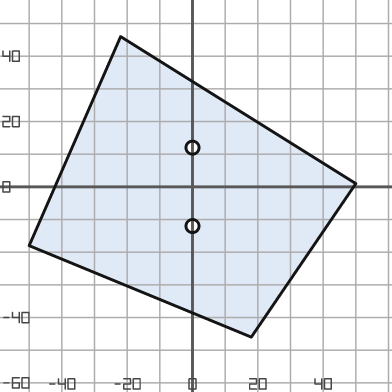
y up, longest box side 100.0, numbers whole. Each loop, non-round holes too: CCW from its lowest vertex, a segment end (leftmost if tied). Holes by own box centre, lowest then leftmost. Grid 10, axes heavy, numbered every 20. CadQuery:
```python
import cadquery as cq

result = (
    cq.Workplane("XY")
    .moveTo(18.0, -46.0)
    .lineTo(50.0, 1.0)
    .lineTo(-22.0, 46.0)
    .lineTo(-50.0, -18.0)
    .close()
    .moveTo(0.0, -12.0)
    .circle(2.0)
    .moveTo(0.0, 12.0)
    .circle(2.0)
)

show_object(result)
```